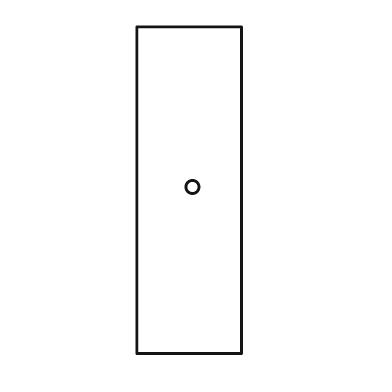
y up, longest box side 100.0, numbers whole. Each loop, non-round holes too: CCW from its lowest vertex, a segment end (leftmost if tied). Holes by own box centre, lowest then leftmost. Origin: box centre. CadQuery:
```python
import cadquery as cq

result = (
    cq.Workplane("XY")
    .moveTo(-16.0, -50.0)
    .lineTo(16.0, -50.0)
    .lineTo(16.0, 50.0)
    .lineTo(-16.0, 50.0)
    .close()
    .moveTo(1.0, 1.0)
    .circle(2.0)
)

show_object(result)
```